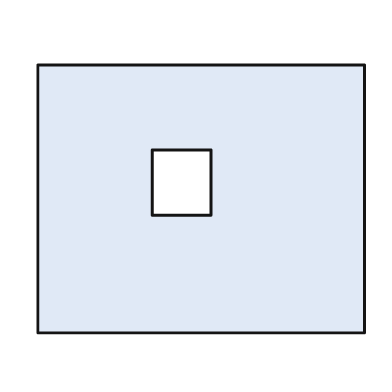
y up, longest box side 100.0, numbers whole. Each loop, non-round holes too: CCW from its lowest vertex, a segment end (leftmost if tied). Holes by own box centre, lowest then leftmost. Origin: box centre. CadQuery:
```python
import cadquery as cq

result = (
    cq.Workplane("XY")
    .moveTo(-50.0, -41.0)
    .lineTo(50.0, -41.0)
    .lineTo(50.0, 41.0)
    .lineTo(-50.0, 41.0)
    .close()
    .moveTo(-15.0, -5.0)
    .lineTo(3.0, -5.0)
    .lineTo(3.0, 15.0)
    .lineTo(-15.0, 15.0)
    .close()
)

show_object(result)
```